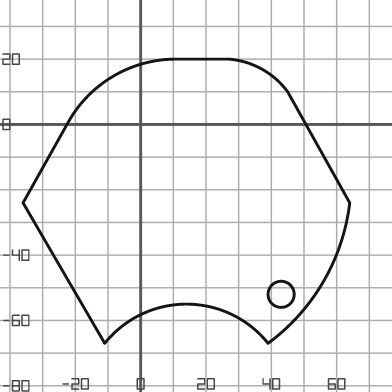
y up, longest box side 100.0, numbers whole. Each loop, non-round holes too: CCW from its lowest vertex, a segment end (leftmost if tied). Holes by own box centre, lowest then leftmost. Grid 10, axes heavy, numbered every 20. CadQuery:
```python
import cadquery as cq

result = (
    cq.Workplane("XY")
    .moveTo(-11.0, -67.0)
    .threePointArc((14.0, -55.0), (39.0, -67.0))
    .threePointArc((56.0, -48.0), (64.0, -24.0))
    .lineTo(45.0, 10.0)
    .threePointArc((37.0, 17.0), (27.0, 20.0))
    .lineTo(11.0, 20.0)
    .threePointArc((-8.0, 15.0), (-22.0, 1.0))
    .lineTo(-36.0, -24.0)
    .close()
    .moveTo(43.0, -52.0)
    .circle(4.0)
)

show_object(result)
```